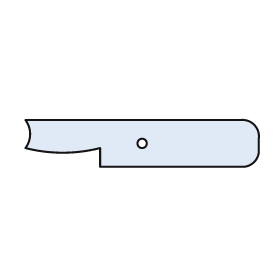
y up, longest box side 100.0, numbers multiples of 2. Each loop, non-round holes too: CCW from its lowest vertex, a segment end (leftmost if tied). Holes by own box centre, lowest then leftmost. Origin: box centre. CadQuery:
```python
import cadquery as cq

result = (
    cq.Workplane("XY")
    .moveTo(-18.0, -10.0)
    .lineTo(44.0, -10.0)
    .threePointArc((48.0, -8.0), (50.0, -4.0))
    .lineTo(50.0, 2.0)
    .threePointArc((48.0, 8.0), (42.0, 10.0))
    .lineTo(-50.0, 10.0)
    .threePointArc((-48.0, 4.0), (-50.0, -2.0))
    .threePointArc((-34.0, -4.0), (-18.0, -2.0))
    .close()
    .moveTo(0.0, 0.0)
    .circle(2.0)
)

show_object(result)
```